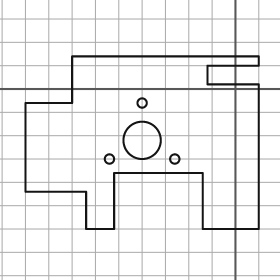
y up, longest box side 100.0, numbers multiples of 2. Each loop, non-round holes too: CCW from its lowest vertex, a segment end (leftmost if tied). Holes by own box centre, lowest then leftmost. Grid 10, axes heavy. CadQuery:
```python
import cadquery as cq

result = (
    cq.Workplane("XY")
    .moveTo(-64.0, -60.0)
    .lineTo(-52.0, -60.0)
    .lineTo(-52.0, -36.0)
    .lineTo(-14.0, -36.0)
    .lineTo(-14.0, -60.0)
    .lineTo(10.0, -60.0)
    .lineTo(10.0, 2.0)
    .lineTo(-12.0, 2.0)
    .lineTo(-12.0, 10.0)
    .lineTo(10.0, 10.0)
    .lineTo(10.0, 14.0)
    .lineTo(-70.0, 14.0)
    .lineTo(-70.0, -6.0)
    .lineTo(-90.0, -6.0)
    .lineTo(-90.0, -44.0)
    .lineTo(-64.0, -44.0)
    .close()
    .moveTo(-54.0, -30.0)
    .circle(2.0)
    .moveTo(-26.0, -30.0)
    .circle(2.0)
    .moveTo(-40.0, -22.0)
    .circle(8.0)
    .moveTo(-40.0, -6.0)
    .circle(2.0)
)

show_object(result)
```